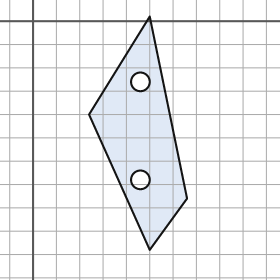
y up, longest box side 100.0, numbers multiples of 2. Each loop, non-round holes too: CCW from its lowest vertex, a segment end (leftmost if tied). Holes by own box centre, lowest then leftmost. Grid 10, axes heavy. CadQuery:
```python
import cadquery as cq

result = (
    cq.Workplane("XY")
    .moveTo(50.0, -98.0)
    .lineTo(66.0, -76.0)
    .lineTo(50.0, 2.0)
    .lineTo(24.0, -40.0)
    .close()
    .moveTo(46.0, -68.0)
    .circle(4.0)
    .moveTo(46.0, -26.0)
    .circle(4.0)
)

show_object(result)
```